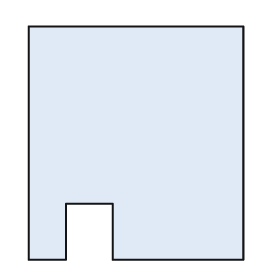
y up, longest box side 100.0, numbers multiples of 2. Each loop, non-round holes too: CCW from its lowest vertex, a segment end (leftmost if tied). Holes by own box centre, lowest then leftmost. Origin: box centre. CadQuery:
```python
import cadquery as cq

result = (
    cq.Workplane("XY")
    .moveTo(-46.0, -50.0)
    .lineTo(-30.0, -50.0)
    .lineTo(-30.0, -26.0)
    .lineTo(-10.0, -26.0)
    .lineTo(-10.0, -50.0)
    .lineTo(46.0, -50.0)
    .lineTo(46.0, 50.0)
    .lineTo(-46.0, 50.0)
    .close()
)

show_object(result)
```